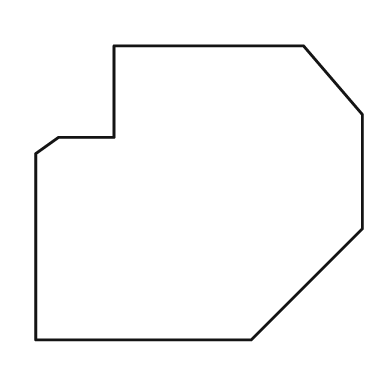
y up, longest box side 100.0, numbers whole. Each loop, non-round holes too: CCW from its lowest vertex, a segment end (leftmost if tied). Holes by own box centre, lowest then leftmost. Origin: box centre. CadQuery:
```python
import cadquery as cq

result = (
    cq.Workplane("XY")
    .moveTo(-50.0, -45.0)
    .lineTo(16.0, -45.0)
    .lineTo(50.0, -11.0)
    .lineTo(50.0, 24.0)
    .lineTo(32.0, 45.0)
    .lineTo(-26.0, 45.0)
    .lineTo(-26.0, 17.0)
    .lineTo(-43.0, 17.0)
    .lineTo(-50.0, 12.0)
    .close()
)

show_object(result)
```